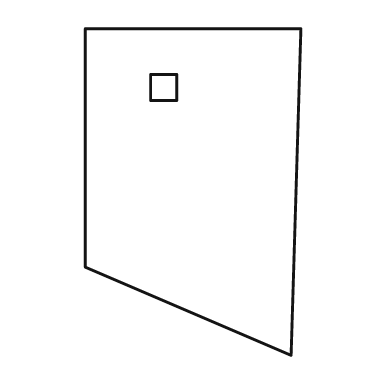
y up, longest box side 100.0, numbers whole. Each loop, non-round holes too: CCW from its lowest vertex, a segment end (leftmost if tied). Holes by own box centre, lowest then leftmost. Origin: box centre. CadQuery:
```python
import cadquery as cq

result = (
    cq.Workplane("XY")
    .moveTo(30.0, -50.0)
    .lineTo(33.0, 50.0)
    .lineTo(-33.0, 50.0)
    .lineTo(-33.0, -23.0)
    .close()
    .moveTo(-13.0, 28.0)
    .lineTo(-5.0, 28.0)
    .lineTo(-5.0, 36.0)
    .lineTo(-13.0, 36.0)
    .close()
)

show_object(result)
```